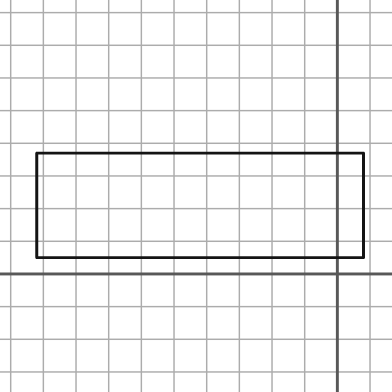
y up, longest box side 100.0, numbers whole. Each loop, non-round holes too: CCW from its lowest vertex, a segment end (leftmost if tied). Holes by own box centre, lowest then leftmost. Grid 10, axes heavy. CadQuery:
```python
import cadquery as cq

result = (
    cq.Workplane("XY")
    .moveTo(-92.0, 5.0)
    .lineTo(8.0, 5.0)
    .lineTo(8.0, 37.0)
    .lineTo(-92.0, 37.0)
    .close()
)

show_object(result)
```